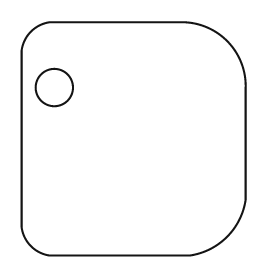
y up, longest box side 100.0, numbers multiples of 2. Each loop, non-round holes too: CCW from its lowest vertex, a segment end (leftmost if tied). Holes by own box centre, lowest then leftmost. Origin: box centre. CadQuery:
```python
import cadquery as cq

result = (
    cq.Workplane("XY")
    .moveTo(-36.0, -50.0)
    .lineTo(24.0, -50.0)
    .threePointArc((40.0, -42.0), (48.0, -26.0))
    .lineTo(48.0, 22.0)
    .threePointArc((40.0, 42.0), (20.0, 50.0))
    .lineTo(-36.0, 50.0)
    .threePointArc((-44.0, 46.0), (-48.0, 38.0))
    .lineTo(-48.0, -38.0)
    .threePointArc((-44.0, -46.0), (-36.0, -50.0))
    .close()
    .moveTo(-34.0, 22.0)
    .circle(8.0)
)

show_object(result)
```